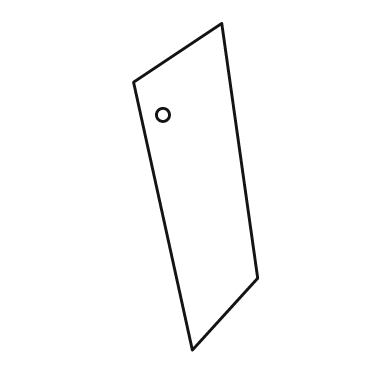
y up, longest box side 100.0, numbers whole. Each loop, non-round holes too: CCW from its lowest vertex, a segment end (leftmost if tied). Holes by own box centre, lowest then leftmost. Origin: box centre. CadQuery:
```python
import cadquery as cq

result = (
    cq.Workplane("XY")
    .moveTo(-1.0, -50.0)
    .lineTo(19.0, -28.0)
    .lineTo(8.0, 50.0)
    .lineTo(-19.0, 32.0)
    .close()
    .moveTo(-10.0, 22.0)
    .circle(2.0)
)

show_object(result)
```